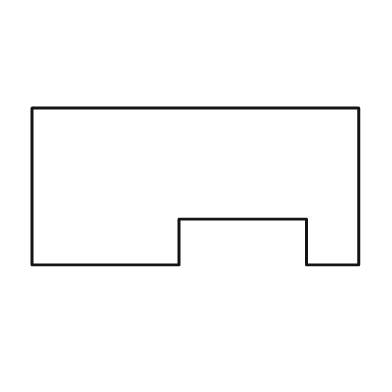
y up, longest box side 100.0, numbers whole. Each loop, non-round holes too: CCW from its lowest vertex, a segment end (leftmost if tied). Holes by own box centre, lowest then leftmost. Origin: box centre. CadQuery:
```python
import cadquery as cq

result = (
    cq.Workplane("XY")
    .moveTo(-50.0, -24.0)
    .lineTo(-5.0, -24.0)
    .lineTo(-5.0, -10.0)
    .lineTo(34.0, -10.0)
    .lineTo(34.0, -24.0)
    .lineTo(50.0, -24.0)
    .lineTo(50.0, 24.0)
    .lineTo(-50.0, 24.0)
    .close()
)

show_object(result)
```